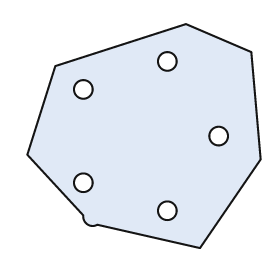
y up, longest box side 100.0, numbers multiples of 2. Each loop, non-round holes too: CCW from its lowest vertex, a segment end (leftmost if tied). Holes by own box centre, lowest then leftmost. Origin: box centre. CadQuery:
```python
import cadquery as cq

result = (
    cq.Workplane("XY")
    .moveTo(24.0, -48.0)
    .lineTo(50.0, -10.0)
    .lineTo(46.0, 36.0)
    .lineTo(18.0, 48.0)
    .lineTo(-38.0, 30.0)
    .lineTo(-50.0, -8.0)
    .lineTo(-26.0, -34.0)
    .threePointArc((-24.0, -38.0), (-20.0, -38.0))
    .close()
    .moveTo(10.0, -32.0)
    .circle(4.0)
    .moveTo(-26.0, -20.0)
    .circle(4.0)
    .moveTo(32.0, 0.0)
    .circle(4.0)
    .moveTo(-26.0, 20.0)
    .circle(4.0)
    .moveTo(10.0, 32.0)
    .circle(4.0)
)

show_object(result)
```